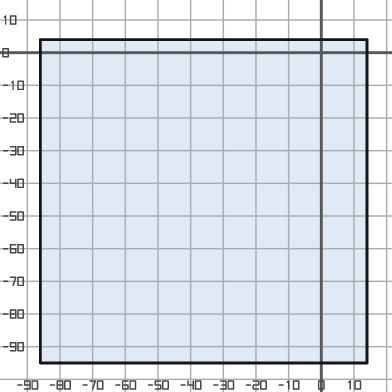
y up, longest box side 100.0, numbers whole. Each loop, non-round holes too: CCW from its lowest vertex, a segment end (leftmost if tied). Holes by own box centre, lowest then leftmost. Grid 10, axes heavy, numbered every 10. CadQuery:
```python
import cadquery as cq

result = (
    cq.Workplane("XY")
    .moveTo(-86.0, -95.0)
    .lineTo(14.0, -95.0)
    .lineTo(14.0, 4.0)
    .lineTo(-86.0, 4.0)
    .close()
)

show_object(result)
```